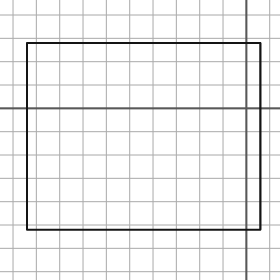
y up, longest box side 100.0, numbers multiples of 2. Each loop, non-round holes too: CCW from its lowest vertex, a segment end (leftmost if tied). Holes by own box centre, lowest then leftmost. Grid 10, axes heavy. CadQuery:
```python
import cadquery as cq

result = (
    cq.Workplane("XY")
    .moveTo(-94.0, -52.0)
    .lineTo(6.0, -52.0)
    .lineTo(6.0, 28.0)
    .lineTo(-94.0, 28.0)
    .close()
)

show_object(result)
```